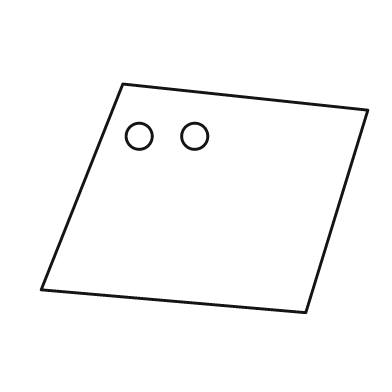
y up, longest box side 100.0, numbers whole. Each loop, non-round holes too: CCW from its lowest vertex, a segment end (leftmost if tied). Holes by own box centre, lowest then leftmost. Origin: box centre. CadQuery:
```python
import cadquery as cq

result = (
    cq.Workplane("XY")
    .moveTo(31.0, -35.0)
    .lineTo(50.0, 27.0)
    .lineTo(-25.0, 35.0)
    .lineTo(-50.0, -28.0)
    .close()
    .moveTo(-20.0, 19.0)
    .circle(4.0)
    .moveTo(-3.0, 19.0)
    .circle(4.0)
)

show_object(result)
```